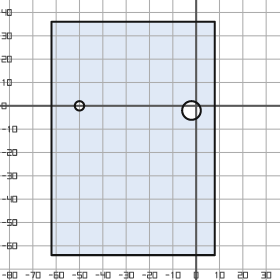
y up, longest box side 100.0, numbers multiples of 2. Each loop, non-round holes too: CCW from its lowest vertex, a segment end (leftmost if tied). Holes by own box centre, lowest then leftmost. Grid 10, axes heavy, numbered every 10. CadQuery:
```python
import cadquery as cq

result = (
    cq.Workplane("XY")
    .moveTo(-62.0, -64.0)
    .lineTo(8.0, -64.0)
    .lineTo(8.0, 36.0)
    .lineTo(-62.0, 36.0)
    .close()
    .moveTo(-2.0, -2.0)
    .circle(4.0)
    .moveTo(-50.0, 0.0)
    .circle(2.0)
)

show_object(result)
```